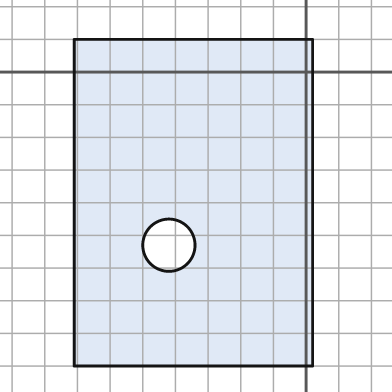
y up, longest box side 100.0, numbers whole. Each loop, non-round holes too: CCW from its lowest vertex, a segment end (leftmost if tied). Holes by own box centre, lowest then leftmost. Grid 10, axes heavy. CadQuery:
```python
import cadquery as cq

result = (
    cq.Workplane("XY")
    .moveTo(-71.0, -90.0)
    .lineTo(2.0, -90.0)
    .lineTo(2.0, 10.0)
    .lineTo(-71.0, 10.0)
    .close()
    .moveTo(-42.0, -53.0)
    .circle(8.0)
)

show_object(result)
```